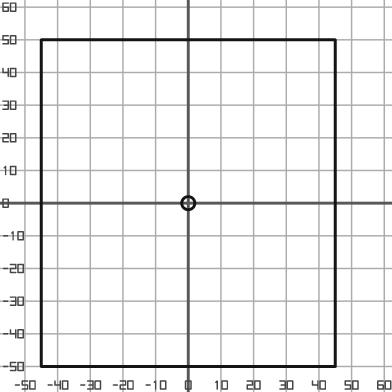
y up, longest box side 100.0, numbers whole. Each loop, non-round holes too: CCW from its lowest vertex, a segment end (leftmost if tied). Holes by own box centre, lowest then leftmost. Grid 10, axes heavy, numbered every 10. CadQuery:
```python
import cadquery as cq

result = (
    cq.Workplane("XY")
    .moveTo(-45.0, -50.0)
    .lineTo(45.0, -50.0)
    .lineTo(45.0, 50.0)
    .lineTo(-45.0, 50.0)
    .close()
    .moveTo(0.0, 0.0)
    .circle(2.0)
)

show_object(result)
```